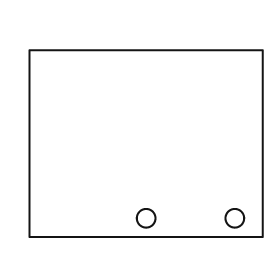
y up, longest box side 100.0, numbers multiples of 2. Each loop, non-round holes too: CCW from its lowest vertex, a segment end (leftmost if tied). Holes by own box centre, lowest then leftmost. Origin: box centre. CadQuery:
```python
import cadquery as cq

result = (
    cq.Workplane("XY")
    .moveTo(-50.0, -40.0)
    .lineTo(50.0, -40.0)
    .lineTo(50.0, 40.0)
    .lineTo(-50.0, 40.0)
    .close()
    .moveTo(0.0, -32.0)
    .circle(4.0)
    .moveTo(38.0, -32.0)
    .circle(4.0)
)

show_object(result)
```